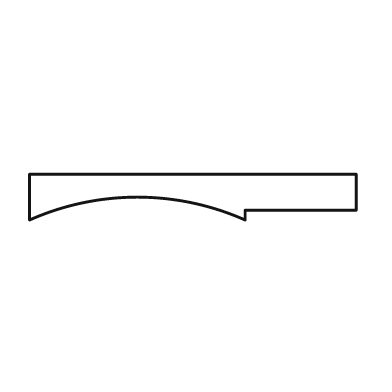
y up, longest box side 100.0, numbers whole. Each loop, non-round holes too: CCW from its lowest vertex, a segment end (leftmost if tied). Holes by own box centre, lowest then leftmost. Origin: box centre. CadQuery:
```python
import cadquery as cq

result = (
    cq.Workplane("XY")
    .moveTo(-50.0, -7.0)
    .threePointArc((-17.0, 0.0), (16.0, -7.0))
    .lineTo(16.0, -4.0)
    .lineTo(50.0, -4.0)
    .lineTo(50.0, 7.0)
    .lineTo(-50.0, 7.0)
    .close()
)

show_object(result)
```